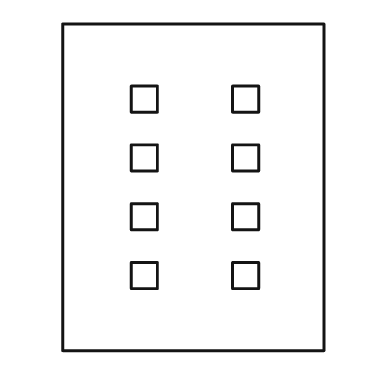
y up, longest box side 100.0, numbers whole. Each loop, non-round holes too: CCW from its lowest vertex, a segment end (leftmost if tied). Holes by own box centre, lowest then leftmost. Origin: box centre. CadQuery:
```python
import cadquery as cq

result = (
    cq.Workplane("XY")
    .moveTo(-40.0, -50.0)
    .lineTo(40.0, -50.0)
    .lineTo(40.0, 50.0)
    .lineTo(-40.0, 50.0)
    .close()
    .moveTo(-19.0, -31.0)
    .lineTo(-11.0, -31.0)
    .lineTo(-11.0, -23.0)
    .lineTo(-19.0, -23.0)
    .close()
    .moveTo(12.0, -31.0)
    .lineTo(20.0, -31.0)
    .lineTo(20.0, -23.0)
    .lineTo(12.0, -23.0)
    .close()
    .moveTo(-19.0, -13.0)
    .lineTo(-11.0, -13.0)
    .lineTo(-11.0, -5.0)
    .lineTo(-19.0, -5.0)
    .close()
    .moveTo(12.0, -13.0)
    .lineTo(20.0, -13.0)
    .lineTo(20.0, -5.0)
    .lineTo(12.0, -5.0)
    .close()
    .moveTo(-19.0, 5.0)
    .lineTo(-11.0, 5.0)
    .lineTo(-11.0, 13.0)
    .lineTo(-19.0, 13.0)
    .close()
    .moveTo(12.0, 5.0)
    .lineTo(20.0, 5.0)
    .lineTo(20.0, 13.0)
    .lineTo(12.0, 13.0)
    .close()
    .moveTo(-19.0, 23.0)
    .lineTo(-11.0, 23.0)
    .lineTo(-11.0, 31.0)
    .lineTo(-19.0, 31.0)
    .close()
    .moveTo(12.0, 23.0)
    .lineTo(20.0, 23.0)
    .lineTo(20.0, 31.0)
    .lineTo(12.0, 31.0)
    .close()
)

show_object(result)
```